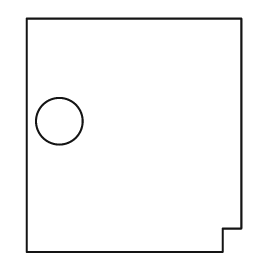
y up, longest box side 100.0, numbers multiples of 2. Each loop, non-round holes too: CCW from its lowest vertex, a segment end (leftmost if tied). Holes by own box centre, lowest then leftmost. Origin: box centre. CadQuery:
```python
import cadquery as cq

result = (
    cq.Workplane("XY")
    .moveTo(-46.0, -50.0)
    .lineTo(38.0, -50.0)
    .lineTo(38.0, -40.0)
    .lineTo(46.0, -40.0)
    .lineTo(46.0, 50.0)
    .lineTo(-46.0, 50.0)
    .close()
    .moveTo(-32.0, 6.0)
    .circle(10.0)
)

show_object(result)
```